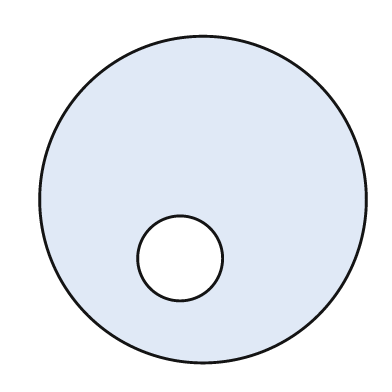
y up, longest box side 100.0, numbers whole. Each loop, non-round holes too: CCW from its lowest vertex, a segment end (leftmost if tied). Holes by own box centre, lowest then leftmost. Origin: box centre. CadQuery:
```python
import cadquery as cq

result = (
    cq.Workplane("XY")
    .moveTo(0.0, 0.0)
    .circle(50.0)
    .moveTo(-7.0, -18.0)
    .circle(13.0)
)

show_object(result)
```